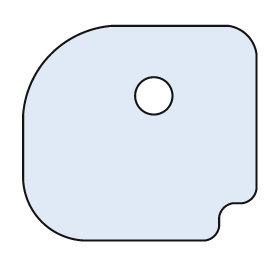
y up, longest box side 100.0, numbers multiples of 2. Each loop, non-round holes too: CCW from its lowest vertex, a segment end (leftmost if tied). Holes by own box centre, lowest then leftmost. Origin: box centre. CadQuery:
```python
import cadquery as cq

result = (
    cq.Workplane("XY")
    .moveTo(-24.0, -46.0)
    .lineTo(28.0, -46.0)
    .threePointArc((32.0, -44.0), (34.0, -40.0))
    .lineTo(34.0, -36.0)
    .threePointArc((36.0, -32.0), (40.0, -30.0))
    .lineTo(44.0, -30.0)
    .threePointArc((48.0, -28.0), (50.0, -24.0))
    .lineTo(50.0, 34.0)
    .threePointArc((46.0, 42.0), (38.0, 46.0))
    .lineTo(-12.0, 46.0)
    .threePointArc((-38.0, 34.0), (-50.0, 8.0))
    .lineTo(-50.0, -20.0)
    .threePointArc((-42.0, -38.0), (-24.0, -46.0))
    .close()
    .moveTo(6.0, 16.0)
    .circle(8.0)
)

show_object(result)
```